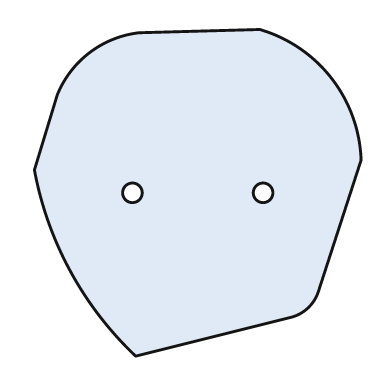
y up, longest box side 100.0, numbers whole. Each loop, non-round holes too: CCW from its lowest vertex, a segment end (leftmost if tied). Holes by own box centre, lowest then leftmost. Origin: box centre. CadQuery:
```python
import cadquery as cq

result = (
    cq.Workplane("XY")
    .moveTo(-19.0, -50.0)
    .lineTo(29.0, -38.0)
    .threePointArc((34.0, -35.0), (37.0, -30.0))
    .lineTo(50.0, 10.0)
    .threePointArc((41.0, 35.0), (19.0, 50.0))
    .lineTo(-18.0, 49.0)
    .threePointArc((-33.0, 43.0), (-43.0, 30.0))
    .lineTo(-50.0, 7.0)
    .threePointArc((-39.0, -24.0), (-19.0, -50.0))
    .close()
    .moveTo(-20.0, 0.0)
    .circle(3.0)
    .moveTo(20.0, 0.0)
    .circle(3.0)
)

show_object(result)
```